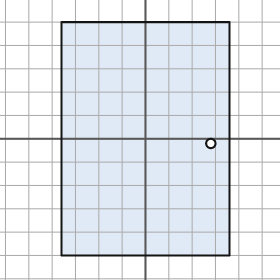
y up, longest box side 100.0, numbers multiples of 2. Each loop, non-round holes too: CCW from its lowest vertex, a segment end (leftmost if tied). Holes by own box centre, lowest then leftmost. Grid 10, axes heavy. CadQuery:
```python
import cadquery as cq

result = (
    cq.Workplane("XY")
    .moveTo(-36.0, -50.0)
    .lineTo(36.0, -50.0)
    .lineTo(36.0, 50.0)
    .lineTo(-36.0, 50.0)
    .close()
    .moveTo(28.0, -2.0)
    .circle(2.0)
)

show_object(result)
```